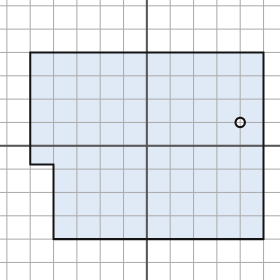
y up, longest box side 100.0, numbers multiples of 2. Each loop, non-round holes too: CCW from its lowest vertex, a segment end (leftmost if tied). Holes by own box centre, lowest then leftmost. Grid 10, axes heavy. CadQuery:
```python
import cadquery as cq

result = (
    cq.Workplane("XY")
    .moveTo(-40.0, -40.0)
    .lineTo(50.0, -40.0)
    .lineTo(50.0, 40.0)
    .lineTo(-50.0, 40.0)
    .lineTo(-50.0, -8.0)
    .lineTo(-40.0, -8.0)
    .close()
    .moveTo(40.0, 10.0)
    .circle(2.0)
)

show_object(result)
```